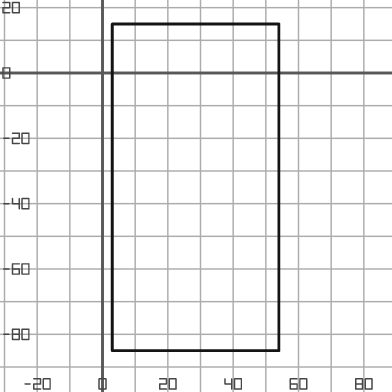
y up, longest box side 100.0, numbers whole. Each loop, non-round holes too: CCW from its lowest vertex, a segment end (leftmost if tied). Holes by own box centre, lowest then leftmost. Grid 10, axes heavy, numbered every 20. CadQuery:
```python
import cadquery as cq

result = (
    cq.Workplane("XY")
    .moveTo(3.0, -85.0)
    .lineTo(54.0, -85.0)
    .lineTo(54.0, 15.0)
    .lineTo(3.0, 15.0)
    .close()
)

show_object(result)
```